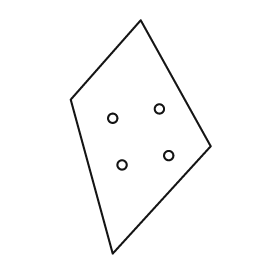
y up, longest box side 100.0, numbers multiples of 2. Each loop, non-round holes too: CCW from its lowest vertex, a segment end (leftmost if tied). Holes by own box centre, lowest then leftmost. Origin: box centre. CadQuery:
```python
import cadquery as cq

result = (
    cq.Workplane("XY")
    .moveTo(-12.0, -50.0)
    .lineTo(30.0, -4.0)
    .lineTo(0.0, 50.0)
    .lineTo(-30.0, 16.0)
    .close()
    .moveTo(-8.0, -12.0)
    .circle(2.0)
    .moveTo(12.0, -8.0)
    .circle(2.0)
    .moveTo(-12.0, 8.0)
    .circle(2.0)
    .moveTo(8.0, 12.0)
    .circle(2.0)
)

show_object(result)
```